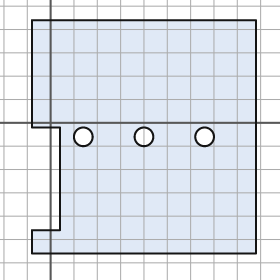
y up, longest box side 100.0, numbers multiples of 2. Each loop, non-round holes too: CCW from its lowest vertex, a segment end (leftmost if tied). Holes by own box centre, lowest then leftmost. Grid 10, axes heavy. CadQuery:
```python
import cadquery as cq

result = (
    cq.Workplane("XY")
    .moveTo(-8.0, -56.0)
    .lineTo(88.0, -56.0)
    .lineTo(88.0, 44.0)
    .lineTo(-8.0, 44.0)
    .lineTo(-8.0, -2.0)
    .lineTo(4.0, -2.0)
    .lineTo(4.0, -46.0)
    .lineTo(-8.0, -46.0)
    .close()
    .moveTo(14.0, -6.0)
    .circle(4.0)
    .moveTo(40.0, -6.0)
    .circle(4.0)
    .moveTo(66.0, -6.0)
    .circle(4.0)
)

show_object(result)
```